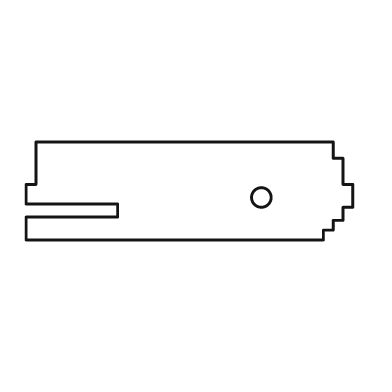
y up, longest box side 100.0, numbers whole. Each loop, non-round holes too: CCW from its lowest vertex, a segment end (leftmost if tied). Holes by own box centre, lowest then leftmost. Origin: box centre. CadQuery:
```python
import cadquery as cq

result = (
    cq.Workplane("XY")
    .moveTo(-50.0, -15.0)
    .lineTo(41.0, -15.0)
    .lineTo(41.0, -12.0)
    .lineTo(44.0, -12.0)
    .lineTo(44.0, -9.0)
    .lineTo(47.0, -9.0)
    .lineTo(47.0, -5.0)
    .lineTo(50.0, -5.0)
    .lineTo(50.0, 2.0)
    .lineTo(47.0, 2.0)
    .lineTo(47.0, 10.0)
    .lineTo(44.0, 10.0)
    .lineTo(44.0, 15.0)
    .lineTo(-47.0, 15.0)
    .lineTo(-47.0, 2.0)
    .lineTo(-50.0, 2.0)
    .lineTo(-50.0, -4.0)
    .lineTo(-22.0, -4.0)
    .lineTo(-22.0, -8.0)
    .lineTo(-50.0, -8.0)
    .close()
    .moveTo(22.0, -2.0)
    .circle(3.0)
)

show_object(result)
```